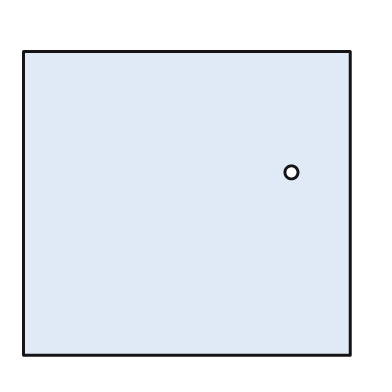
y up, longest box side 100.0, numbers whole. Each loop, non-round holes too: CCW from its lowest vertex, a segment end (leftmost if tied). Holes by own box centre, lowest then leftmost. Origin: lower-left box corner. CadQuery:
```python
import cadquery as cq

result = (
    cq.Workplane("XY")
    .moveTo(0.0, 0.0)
    .lineTo(100.0, 0.0)
    .lineTo(100.0, 93.0)
    .lineTo(0.0, 93.0)
    .close()
    .moveTo(82.0, 56.0)
    .circle(2.0)
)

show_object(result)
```